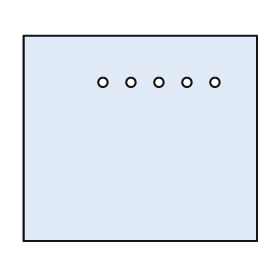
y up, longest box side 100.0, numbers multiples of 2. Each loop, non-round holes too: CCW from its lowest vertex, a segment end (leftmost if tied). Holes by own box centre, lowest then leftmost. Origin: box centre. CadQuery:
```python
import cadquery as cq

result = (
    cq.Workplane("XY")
    .moveTo(-50.0, -44.0)
    .lineTo(50.0, -44.0)
    .lineTo(50.0, 44.0)
    .lineTo(-50.0, 44.0)
    .close()
    .moveTo(-16.0, 24.0)
    .circle(2.0)
    .moveTo(-4.0, 24.0)
    .circle(2.0)
    .moveTo(8.0, 24.0)
    .circle(2.0)
    .moveTo(20.0, 24.0)
    .circle(2.0)
    .moveTo(32.0, 24.0)
    .circle(2.0)
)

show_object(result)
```